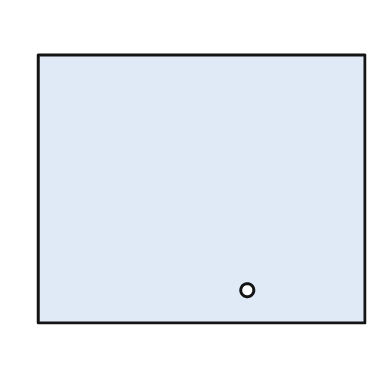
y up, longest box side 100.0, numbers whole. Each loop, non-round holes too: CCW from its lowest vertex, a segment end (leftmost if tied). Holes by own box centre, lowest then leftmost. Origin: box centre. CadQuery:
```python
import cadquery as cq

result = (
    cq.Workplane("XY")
    .moveTo(-50.0, -41.0)
    .lineTo(50.0, -41.0)
    .lineTo(50.0, 41.0)
    .lineTo(-50.0, 41.0)
    .close()
    .moveTo(14.0, -31.0)
    .circle(2.0)
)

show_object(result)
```